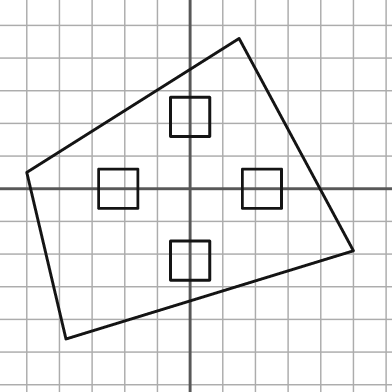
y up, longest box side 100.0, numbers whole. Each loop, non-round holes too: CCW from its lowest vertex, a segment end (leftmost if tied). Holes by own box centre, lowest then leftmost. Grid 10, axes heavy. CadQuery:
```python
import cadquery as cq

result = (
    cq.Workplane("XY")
    .moveTo(-38.0, -46.0)
    .lineTo(50.0, -19.0)
    .lineTo(15.0, 46.0)
    .lineTo(-50.0, 5.0)
    .close()
    .moveTo(-6.0, -28.0)
    .lineTo(6.0, -28.0)
    .lineTo(6.0, -16.0)
    .lineTo(-6.0, -16.0)
    .close()
    .moveTo(-28.0, -6.0)
    .lineTo(-16.0, -6.0)
    .lineTo(-16.0, 6.0)
    .lineTo(-28.0, 6.0)
    .close()
    .moveTo(16.0, -6.0)
    .lineTo(28.0, -6.0)
    .lineTo(28.0, 6.0)
    .lineTo(16.0, 6.0)
    .close()
    .moveTo(-6.0, 16.0)
    .lineTo(6.0, 16.0)
    .lineTo(6.0, 28.0)
    .lineTo(-6.0, 28.0)
    .close()
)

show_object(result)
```